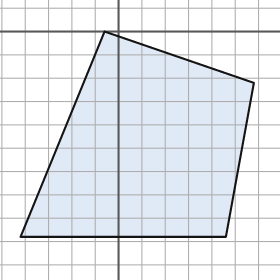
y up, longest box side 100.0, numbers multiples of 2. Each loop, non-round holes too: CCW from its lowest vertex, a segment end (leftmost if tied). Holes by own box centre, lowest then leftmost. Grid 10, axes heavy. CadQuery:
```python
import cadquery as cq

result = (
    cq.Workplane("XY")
    .moveTo(-42.0, -88.0)
    .lineTo(46.0, -88.0)
    .lineTo(58.0, -22.0)
    .lineTo(-6.0, 0.0)
    .close()
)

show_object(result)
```